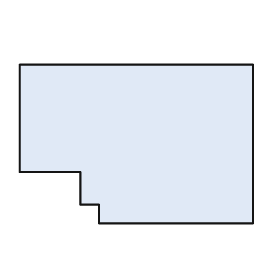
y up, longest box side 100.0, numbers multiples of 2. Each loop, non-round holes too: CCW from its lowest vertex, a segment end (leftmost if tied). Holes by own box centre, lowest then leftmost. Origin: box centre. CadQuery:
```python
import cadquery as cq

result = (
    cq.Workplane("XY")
    .moveTo(-16.0, -34.0)
    .lineTo(50.0, -34.0)
    .lineTo(50.0, 34.0)
    .lineTo(-50.0, 34.0)
    .lineTo(-50.0, -12.0)
    .lineTo(-24.0, -12.0)
    .lineTo(-24.0, -26.0)
    .lineTo(-16.0, -26.0)
    .close()
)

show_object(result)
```